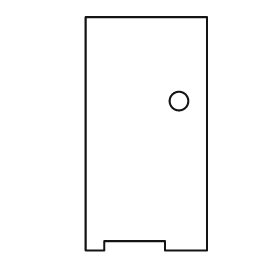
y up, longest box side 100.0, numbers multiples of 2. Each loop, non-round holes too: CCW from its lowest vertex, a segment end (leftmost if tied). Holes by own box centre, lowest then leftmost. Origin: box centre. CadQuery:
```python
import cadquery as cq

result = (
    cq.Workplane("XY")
    .moveTo(-26.0, -50.0)
    .lineTo(-18.0, -50.0)
    .lineTo(-18.0, -46.0)
    .lineTo(8.0, -46.0)
    .lineTo(8.0, -50.0)
    .lineTo(26.0, -50.0)
    .lineTo(26.0, 50.0)
    .lineTo(-26.0, 50.0)
    .close()
    .moveTo(14.0, 14.0)
    .circle(4.0)
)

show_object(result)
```